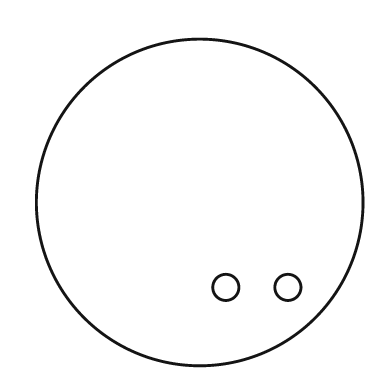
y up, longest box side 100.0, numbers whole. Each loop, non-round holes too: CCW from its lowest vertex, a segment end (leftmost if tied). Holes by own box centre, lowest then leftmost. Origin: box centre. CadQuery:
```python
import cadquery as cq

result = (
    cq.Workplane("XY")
    .moveTo(0.0, 0.0)
    .circle(50.0)
    .moveTo(8.0, -26.0)
    .circle(4.0)
    .moveTo(27.0, -26.0)
    .circle(4.0)
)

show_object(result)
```